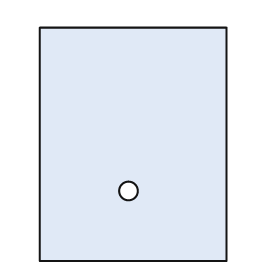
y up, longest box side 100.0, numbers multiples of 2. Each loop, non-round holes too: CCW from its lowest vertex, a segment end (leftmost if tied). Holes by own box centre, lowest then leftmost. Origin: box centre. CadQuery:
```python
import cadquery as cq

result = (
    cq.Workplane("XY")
    .moveTo(-40.0, -50.0)
    .lineTo(40.0, -50.0)
    .lineTo(40.0, 50.0)
    .lineTo(-40.0, 50.0)
    .close()
    .moveTo(-2.0, -20.0)
    .circle(4.0)
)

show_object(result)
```